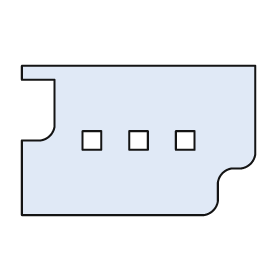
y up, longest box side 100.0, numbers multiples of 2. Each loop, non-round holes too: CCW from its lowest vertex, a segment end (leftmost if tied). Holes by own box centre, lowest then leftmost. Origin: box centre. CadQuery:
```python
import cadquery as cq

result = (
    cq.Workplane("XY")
    .moveTo(-50.0, -32.0)
    .lineTo(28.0, -32.0)
    .threePointArc((32.0, -30.0), (34.0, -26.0))
    .lineTo(34.0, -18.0)
    .threePointArc((36.0, -14.0), (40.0, -12.0))
    .lineTo(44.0, -12.0)
    .threePointArc((48.0, -10.0), (50.0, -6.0))
    .lineTo(50.0, 32.0)
    .lineTo(-50.0, 32.0)
    .lineTo(-50.0, 26.0)
    .lineTo(-36.0, 26.0)
    .lineTo(-36.0, 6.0)
    .threePointArc((-38.0, 2.0), (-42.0, 0.0))
    .lineTo(-50.0, 0.0)
    .close()
    .moveTo(-24.0, -4.0)
    .lineTo(-16.0, -4.0)
    .lineTo(-16.0, 4.0)
    .lineTo(-24.0, 4.0)
    .close()
    .moveTo(-4.0, -4.0)
    .lineTo(4.0, -4.0)
    .lineTo(4.0, 4.0)
    .lineTo(-4.0, 4.0)
    .close()
    .moveTo(16.0, -4.0)
    .lineTo(24.0, -4.0)
    .lineTo(24.0, 4.0)
    .lineTo(16.0, 4.0)
    .close()
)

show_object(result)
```